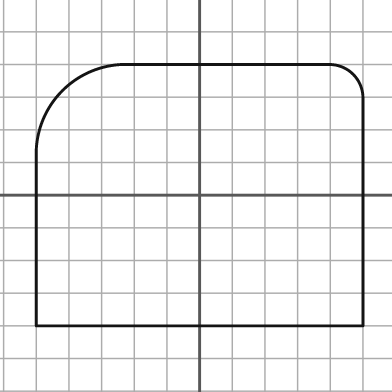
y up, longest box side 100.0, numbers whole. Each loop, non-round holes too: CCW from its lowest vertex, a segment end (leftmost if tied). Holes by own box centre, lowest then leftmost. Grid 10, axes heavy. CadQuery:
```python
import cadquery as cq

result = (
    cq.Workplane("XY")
    .moveTo(-50.0, -40.0)
    .lineTo(50.0, -40.0)
    .lineTo(50.0, 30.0)
    .threePointArc((47.0, 37.0), (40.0, 40.0))
    .lineTo(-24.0, 40.0)
    .threePointArc((-42.0, 32.0), (-50.0, 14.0))
    .close()
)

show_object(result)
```